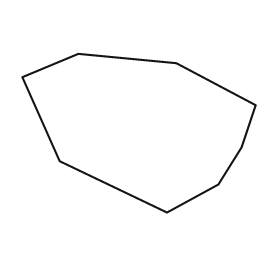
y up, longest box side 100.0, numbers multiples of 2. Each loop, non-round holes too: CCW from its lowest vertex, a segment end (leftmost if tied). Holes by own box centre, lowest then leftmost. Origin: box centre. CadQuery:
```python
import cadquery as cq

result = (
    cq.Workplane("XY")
    .moveTo(12.0, -34.0)
    .lineTo(34.0, -22.0)
    .lineTo(44.0, -6.0)
    .lineTo(50.0, 12.0)
    .lineTo(16.0, 30.0)
    .lineTo(-26.0, 34.0)
    .lineTo(-50.0, 24.0)
    .lineTo(-34.0, -12.0)
    .close()
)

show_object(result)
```